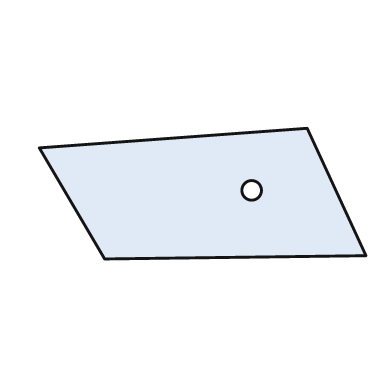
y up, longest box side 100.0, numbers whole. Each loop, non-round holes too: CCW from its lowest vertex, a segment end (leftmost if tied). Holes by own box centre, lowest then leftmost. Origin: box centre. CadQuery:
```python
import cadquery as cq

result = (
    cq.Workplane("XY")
    .moveTo(-30.0, -20.0)
    .lineTo(50.0, -19.0)
    .lineTo(32.0, 20.0)
    .lineTo(-50.0, 14.0)
    .close()
    .moveTo(15.0, 1.0)
    .circle(3.0)
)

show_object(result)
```